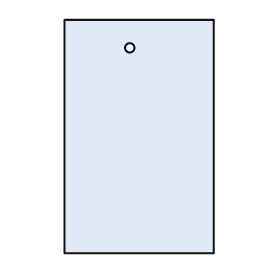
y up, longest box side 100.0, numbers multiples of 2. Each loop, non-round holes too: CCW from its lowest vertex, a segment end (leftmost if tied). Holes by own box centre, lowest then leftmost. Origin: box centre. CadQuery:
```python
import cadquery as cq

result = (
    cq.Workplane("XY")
    .moveTo(-32.0, -50.0)
    .lineTo(32.0, -50.0)
    .lineTo(32.0, 50.0)
    .lineTo(-32.0, 50.0)
    .close()
    .moveTo(-4.0, 38.0)
    .circle(2.0)
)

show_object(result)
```